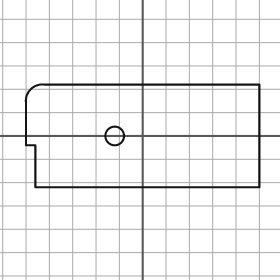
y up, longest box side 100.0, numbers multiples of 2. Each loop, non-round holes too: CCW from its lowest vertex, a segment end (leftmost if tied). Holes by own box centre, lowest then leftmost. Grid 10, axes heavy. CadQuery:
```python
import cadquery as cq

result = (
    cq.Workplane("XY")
    .moveTo(-46.0, -22.0)
    .lineTo(50.0, -22.0)
    .lineTo(50.0, 22.0)
    .lineTo(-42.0, 22.0)
    .threePointArc((-48.0, 20.0), (-50.0, 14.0))
    .lineTo(-50.0, -4.0)
    .lineTo(-46.0, -4.0)
    .close()
    .moveTo(-12.0, 0.0)
    .circle(4.0)
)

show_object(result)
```